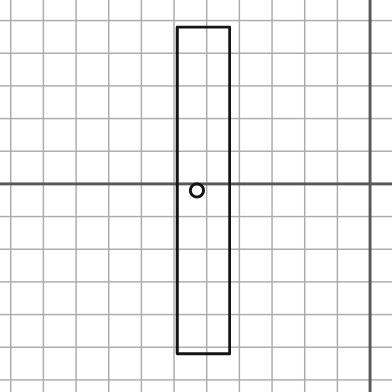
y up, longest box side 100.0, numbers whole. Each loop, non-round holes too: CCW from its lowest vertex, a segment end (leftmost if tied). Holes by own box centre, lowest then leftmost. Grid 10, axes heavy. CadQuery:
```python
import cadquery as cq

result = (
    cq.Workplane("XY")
    .moveTo(-59.0, -52.0)
    .lineTo(-43.0, -52.0)
    .lineTo(-43.0, 48.0)
    .lineTo(-59.0, 48.0)
    .close()
    .moveTo(-53.0, -2.0)
    .circle(2.0)
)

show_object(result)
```